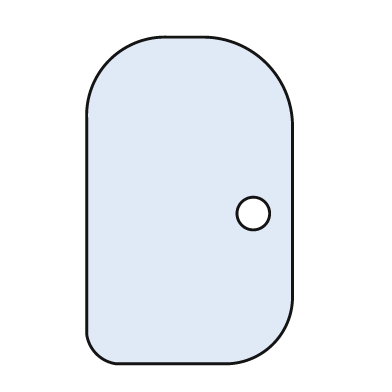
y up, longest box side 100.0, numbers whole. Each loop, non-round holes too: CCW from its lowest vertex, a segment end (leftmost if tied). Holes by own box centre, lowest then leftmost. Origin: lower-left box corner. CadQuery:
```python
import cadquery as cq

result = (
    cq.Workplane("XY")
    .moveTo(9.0, 0.0)
    .lineTo(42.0, 0.0)
    .threePointArc((57.0, 6.0), (63.0, 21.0))
    .lineTo(63.0, 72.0)
    .threePointArc((55.0, 92.0), (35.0, 100.0))
    .lineTo(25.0, 100.0)
    .threePointArc((7.0, 93.0), (0.0, 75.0))
    .lineTo(0.0, 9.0)
    .threePointArc((3.0, 3.0), (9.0, 0.0))
    .close()
    .moveTo(51.0, 46.0)
    .circle(5.0)
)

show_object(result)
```